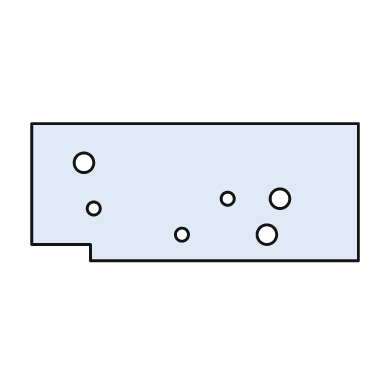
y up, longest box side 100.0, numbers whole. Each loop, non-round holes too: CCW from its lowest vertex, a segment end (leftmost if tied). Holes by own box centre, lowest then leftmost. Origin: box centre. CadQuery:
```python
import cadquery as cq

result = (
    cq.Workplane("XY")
    .moveTo(-32.0, -21.0)
    .lineTo(50.0, -21.0)
    .lineTo(50.0, 21.0)
    .lineTo(-50.0, 21.0)
    .lineTo(-50.0, -16.0)
    .lineTo(-32.0, -16.0)
    .close()
    .moveTo(-4.0, -13.0)
    .circle(2.0)
    .moveTo(22.0, -13.0)
    .circle(3.0)
    .moveTo(-31.0, -5.0)
    .circle(2.0)
    .moveTo(10.0, -2.0)
    .circle(2.0)
    .moveTo(26.0, -2.0)
    .circle(3.0)
    .moveTo(-34.0, 9.0)
    .circle(3.0)
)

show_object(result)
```